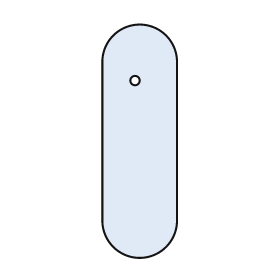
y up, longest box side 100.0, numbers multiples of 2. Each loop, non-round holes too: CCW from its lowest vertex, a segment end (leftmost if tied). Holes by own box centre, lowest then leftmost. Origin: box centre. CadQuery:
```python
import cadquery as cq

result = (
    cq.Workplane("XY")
    .moveTo(-16.0, -34.0)
    .threePointArc((0.0, -50.0), (16.0, -34.0))
    .lineTo(16.0, 34.0)
    .threePointArc((0.0, 50.0), (-16.0, 34.0))
    .close()
    .moveTo(-2.0, 26.0)
    .circle(2.0)
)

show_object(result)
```